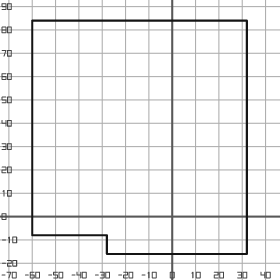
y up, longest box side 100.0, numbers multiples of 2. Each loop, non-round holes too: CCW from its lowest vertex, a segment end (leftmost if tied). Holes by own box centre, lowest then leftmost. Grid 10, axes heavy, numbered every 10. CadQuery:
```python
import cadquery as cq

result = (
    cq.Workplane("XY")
    .moveTo(-28.0, -16.0)
    .lineTo(32.0, -16.0)
    .lineTo(32.0, 84.0)
    .lineTo(-60.0, 84.0)
    .lineTo(-60.0, -8.0)
    .lineTo(-28.0, -8.0)
    .close()
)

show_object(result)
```